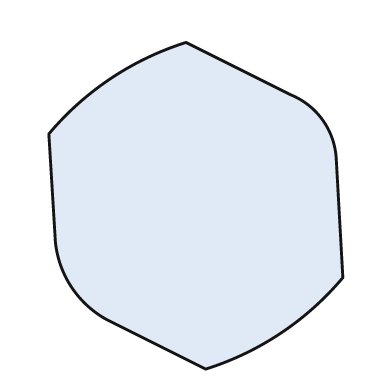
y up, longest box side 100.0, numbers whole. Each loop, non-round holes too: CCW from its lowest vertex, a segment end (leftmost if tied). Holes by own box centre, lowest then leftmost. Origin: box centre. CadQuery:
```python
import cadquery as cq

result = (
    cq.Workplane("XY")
    .moveTo(3.0, -50.0)
    .threePointArc((26.0, -39.0), (45.0, -22.0))
    .lineTo(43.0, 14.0)
    .threePointArc((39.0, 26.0), (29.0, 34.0))
    .lineTo(-3.0, 50.0)
    .threePointArc((-26.0, 39.0), (-45.0, 22.0))
    .lineTo(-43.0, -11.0)
    .threePointArc((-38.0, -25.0), (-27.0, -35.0))
    .close()
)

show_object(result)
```